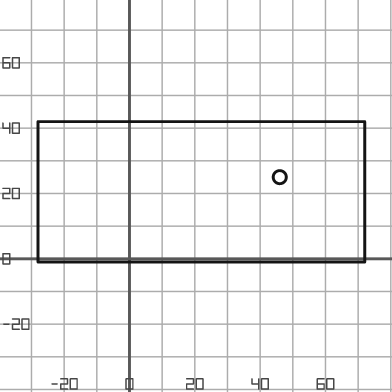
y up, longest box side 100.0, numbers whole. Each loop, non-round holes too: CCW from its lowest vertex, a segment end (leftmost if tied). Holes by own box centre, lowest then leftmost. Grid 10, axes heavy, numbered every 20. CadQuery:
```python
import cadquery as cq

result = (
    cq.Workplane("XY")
    .moveTo(-28.0, -1.0)
    .lineTo(72.0, -1.0)
    .lineTo(72.0, 42.0)
    .lineTo(-28.0, 42.0)
    .close()
    .moveTo(46.0, 25.0)
    .circle(2.0)
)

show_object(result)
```